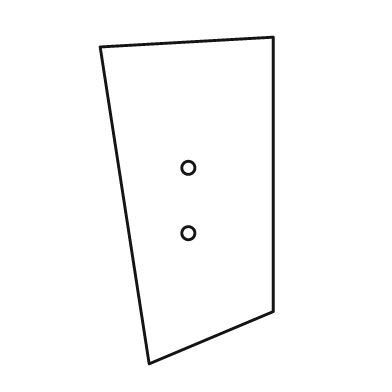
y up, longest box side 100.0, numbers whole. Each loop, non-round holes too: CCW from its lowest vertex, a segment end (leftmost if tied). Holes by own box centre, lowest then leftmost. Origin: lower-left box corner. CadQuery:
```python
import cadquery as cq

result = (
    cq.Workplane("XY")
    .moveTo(15.0, 0.0)
    .lineTo(53.0, 16.0)
    .lineTo(53.0, 100.0)
    .lineTo(0.0, 97.0)
    .close()
    .moveTo(27.0, 40.0)
    .circle(2.0)
    .moveTo(27.0, 60.0)
    .circle(2.0)
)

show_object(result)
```